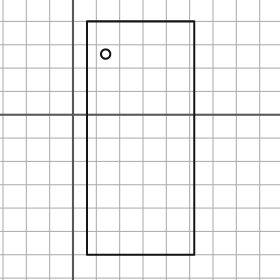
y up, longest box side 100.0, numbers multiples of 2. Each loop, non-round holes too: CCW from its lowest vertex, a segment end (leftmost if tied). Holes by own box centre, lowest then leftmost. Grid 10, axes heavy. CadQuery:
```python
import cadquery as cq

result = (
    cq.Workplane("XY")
    .moveTo(6.0, -60.0)
    .lineTo(52.0, -60.0)
    .lineTo(52.0, 40.0)
    .lineTo(6.0, 40.0)
    .close()
    .moveTo(14.0, 26.0)
    .circle(2.0)
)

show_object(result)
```